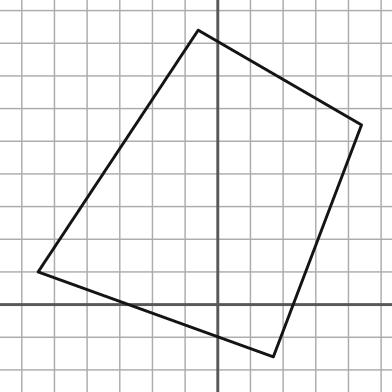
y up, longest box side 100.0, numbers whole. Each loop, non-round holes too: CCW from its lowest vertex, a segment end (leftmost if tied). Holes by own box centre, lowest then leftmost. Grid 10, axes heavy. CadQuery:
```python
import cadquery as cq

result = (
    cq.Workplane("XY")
    .moveTo(17.0, -16.0)
    .lineTo(44.0, 55.0)
    .lineTo(-6.0, 84.0)
    .lineTo(-55.0, 10.0)
    .close()
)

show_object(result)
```